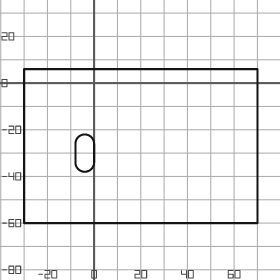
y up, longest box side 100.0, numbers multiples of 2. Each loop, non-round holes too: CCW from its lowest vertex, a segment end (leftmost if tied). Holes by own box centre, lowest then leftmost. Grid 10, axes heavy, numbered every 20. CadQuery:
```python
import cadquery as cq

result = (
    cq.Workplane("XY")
    .moveTo(-30.0, -60.0)
    .lineTo(70.0, -60.0)
    .lineTo(70.0, 6.0)
    .lineTo(-30.0, 6.0)
    .close()
    .moveTo(-8.0, -34.0)
    .threePointArc((-4.0, -38.0), (0.0, -34.0))
    .lineTo(0.0, -26.0)
    .threePointArc((-4.0, -22.0), (-8.0, -26.0))
    .close()
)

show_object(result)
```